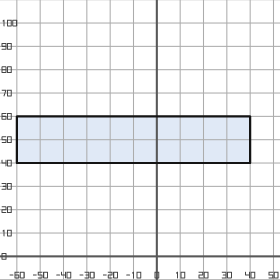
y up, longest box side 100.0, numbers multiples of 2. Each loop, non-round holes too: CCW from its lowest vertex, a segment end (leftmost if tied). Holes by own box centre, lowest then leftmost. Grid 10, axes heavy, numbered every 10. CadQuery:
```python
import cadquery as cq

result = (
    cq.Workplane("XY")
    .moveTo(-60.0, 40.0)
    .lineTo(40.0, 40.0)
    .lineTo(40.0, 60.0)
    .lineTo(-60.0, 60.0)
    .close()
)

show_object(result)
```